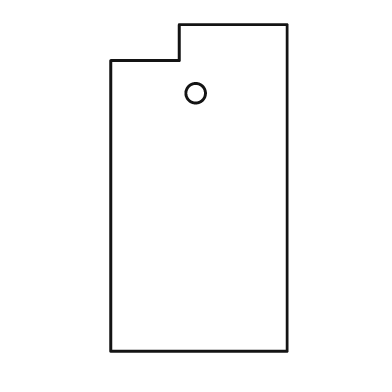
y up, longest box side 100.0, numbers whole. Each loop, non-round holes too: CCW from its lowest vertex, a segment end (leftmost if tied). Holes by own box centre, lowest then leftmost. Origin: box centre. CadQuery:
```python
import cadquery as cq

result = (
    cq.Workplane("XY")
    .moveTo(-27.0, -50.0)
    .lineTo(27.0, -50.0)
    .lineTo(27.0, 50.0)
    .lineTo(-6.0, 50.0)
    .lineTo(-6.0, 39.0)
    .lineTo(-27.0, 39.0)
    .close()
    .moveTo(-1.0, 29.0)
    .circle(3.0)
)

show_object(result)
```